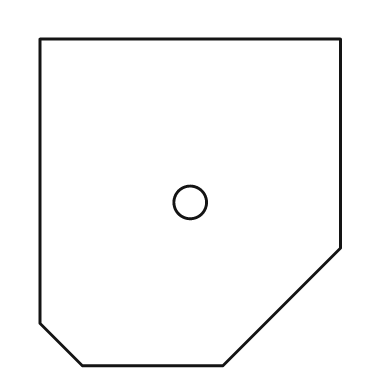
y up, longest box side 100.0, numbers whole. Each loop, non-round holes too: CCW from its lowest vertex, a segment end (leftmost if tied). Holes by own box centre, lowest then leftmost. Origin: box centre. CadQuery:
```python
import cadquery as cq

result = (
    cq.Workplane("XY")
    .moveTo(-33.0, -50.0)
    .lineTo(10.0, -50.0)
    .lineTo(46.0, -14.0)
    .lineTo(46.0, 50.0)
    .lineTo(-46.0, 50.0)
    .lineTo(-46.0, -37.0)
    .close()
    .moveTo(0.0, 0.0)
    .circle(5.0)
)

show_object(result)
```